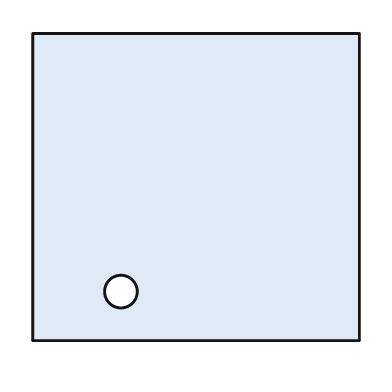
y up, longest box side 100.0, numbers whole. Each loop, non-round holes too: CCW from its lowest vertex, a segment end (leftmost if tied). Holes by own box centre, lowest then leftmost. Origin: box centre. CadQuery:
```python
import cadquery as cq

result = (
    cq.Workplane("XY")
    .moveTo(-50.0, -47.0)
    .lineTo(50.0, -47.0)
    .lineTo(50.0, 47.0)
    .lineTo(-50.0, 47.0)
    .close()
    .moveTo(-23.0, -32.0)
    .circle(5.0)
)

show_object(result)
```